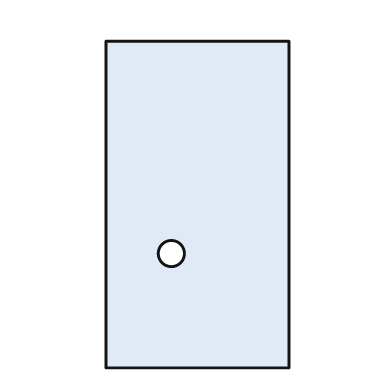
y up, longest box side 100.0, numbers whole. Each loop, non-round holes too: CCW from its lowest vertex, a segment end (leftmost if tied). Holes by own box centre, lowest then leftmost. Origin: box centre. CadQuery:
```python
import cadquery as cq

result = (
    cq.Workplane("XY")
    .moveTo(-28.0, -50.0)
    .lineTo(28.0, -50.0)
    .lineTo(28.0, 50.0)
    .lineTo(-28.0, 50.0)
    .close()
    .moveTo(-8.0, -15.0)
    .circle(4.0)
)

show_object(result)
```